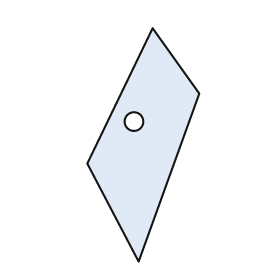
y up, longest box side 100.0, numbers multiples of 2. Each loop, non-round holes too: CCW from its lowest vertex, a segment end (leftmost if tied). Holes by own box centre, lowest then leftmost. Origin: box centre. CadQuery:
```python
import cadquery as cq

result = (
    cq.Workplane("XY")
    .moveTo(-2.0, -50.0)
    .lineTo(24.0, 22.0)
    .lineTo(4.0, 50.0)
    .lineTo(-24.0, -8.0)
    .close()
    .moveTo(-4.0, 10.0)
    .circle(4.0)
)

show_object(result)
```